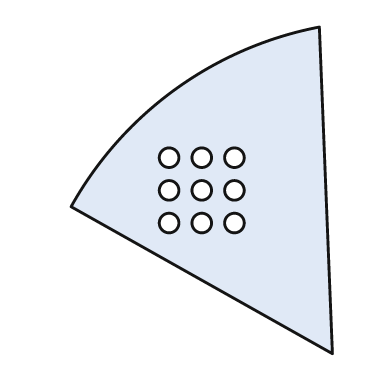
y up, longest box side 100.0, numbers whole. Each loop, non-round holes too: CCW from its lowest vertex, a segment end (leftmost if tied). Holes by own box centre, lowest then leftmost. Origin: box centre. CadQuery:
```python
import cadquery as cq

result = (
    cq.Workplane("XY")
    .moveTo(40.0, -50.0)
    .lineTo(36.0, 50.0)
    .threePointArc((-8.0, 31.0), (-40.0, -5.0))
    .close()
    .moveTo(-10.0, -10.0)
    .circle(3.0)
    .moveTo(0.0, -10.0)
    .circle(3.0)
    .moveTo(10.0, -10.0)
    .circle(3.0)
    .moveTo(-10.0, 0.0)
    .circle(3.0)
    .moveTo(0.0, 0.0)
    .circle(3.0)
    .moveTo(10.0, 0.0)
    .circle(3.0)
    .moveTo(-10.0, 10.0)
    .circle(3.0)
    .moveTo(0.0, 10.0)
    .circle(3.0)
    .moveTo(10.0, 10.0)
    .circle(3.0)
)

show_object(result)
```